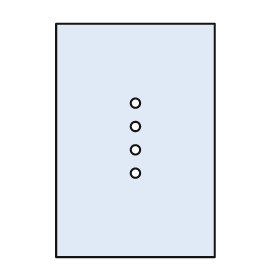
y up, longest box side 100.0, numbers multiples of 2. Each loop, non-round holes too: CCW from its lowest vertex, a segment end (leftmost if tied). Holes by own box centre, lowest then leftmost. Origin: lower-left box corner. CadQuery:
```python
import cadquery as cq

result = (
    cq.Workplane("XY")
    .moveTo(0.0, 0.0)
    .lineTo(68.0, 0.0)
    .lineTo(68.0, 100.0)
    .lineTo(0.0, 100.0)
    .close()
    .moveTo(34.0, 36.0)
    .circle(2.0)
    .moveTo(34.0, 46.0)
    .circle(2.0)
    .moveTo(34.0, 56.0)
    .circle(2.0)
    .moveTo(34.0, 66.0)
    .circle(2.0)
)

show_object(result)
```